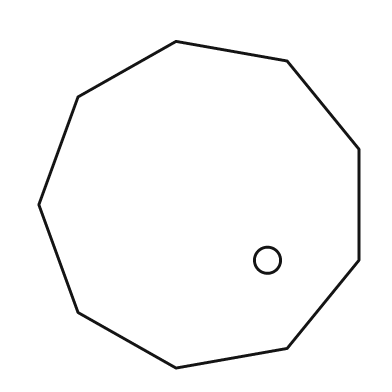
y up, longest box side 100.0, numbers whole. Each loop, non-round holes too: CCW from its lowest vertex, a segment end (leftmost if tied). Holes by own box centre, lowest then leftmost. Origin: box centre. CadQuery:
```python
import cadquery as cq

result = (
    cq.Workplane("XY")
    .moveTo(-7.0, -50.0)
    .lineTo(27.0, -44.0)
    .lineTo(49.0, -17.0)
    .lineTo(49.0, 17.0)
    .lineTo(27.0, 44.0)
    .lineTo(-7.0, 50.0)
    .lineTo(-37.0, 33.0)
    .lineTo(-49.0, 0.0)
    .lineTo(-37.0, -33.0)
    .close()
    .moveTo(21.0, -17.0)
    .circle(4.0)
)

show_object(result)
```